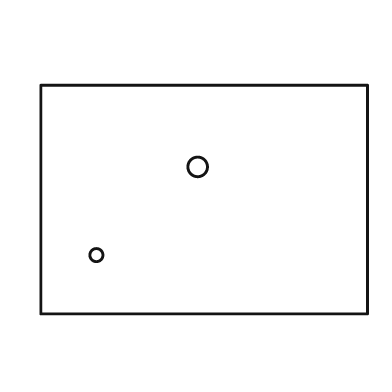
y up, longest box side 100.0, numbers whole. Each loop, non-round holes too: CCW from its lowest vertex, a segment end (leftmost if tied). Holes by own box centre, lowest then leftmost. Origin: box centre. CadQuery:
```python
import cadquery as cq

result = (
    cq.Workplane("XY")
    .moveTo(-50.0, -35.0)
    .lineTo(50.0, -35.0)
    .lineTo(50.0, 35.0)
    .lineTo(-50.0, 35.0)
    .close()
    .moveTo(-33.0, -17.0)
    .circle(2.0)
    .moveTo(-2.0, 10.0)
    .circle(3.0)
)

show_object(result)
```